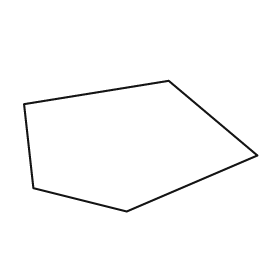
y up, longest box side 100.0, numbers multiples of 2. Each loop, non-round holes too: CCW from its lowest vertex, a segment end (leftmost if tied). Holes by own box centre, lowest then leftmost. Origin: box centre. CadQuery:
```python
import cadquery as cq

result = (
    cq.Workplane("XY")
    .moveTo(-6.0, -28.0)
    .lineTo(50.0, -4.0)
    .lineTo(12.0, 28.0)
    .lineTo(-50.0, 18.0)
    .lineTo(-46.0, -18.0)
    .close()
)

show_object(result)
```